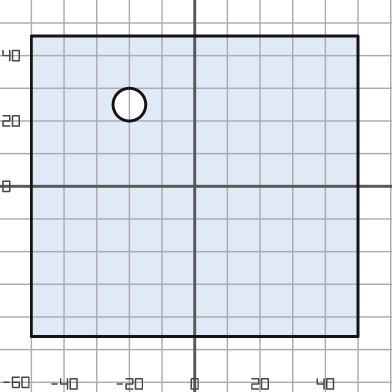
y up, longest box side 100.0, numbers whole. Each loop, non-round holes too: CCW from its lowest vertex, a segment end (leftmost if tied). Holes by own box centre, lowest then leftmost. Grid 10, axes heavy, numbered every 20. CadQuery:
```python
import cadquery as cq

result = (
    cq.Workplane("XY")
    .moveTo(-50.0, -46.0)
    .lineTo(50.0, -46.0)
    .lineTo(50.0, 46.0)
    .lineTo(-50.0, 46.0)
    .close()
    .moveTo(-20.0, 25.0)
    .circle(5.0)
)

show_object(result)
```